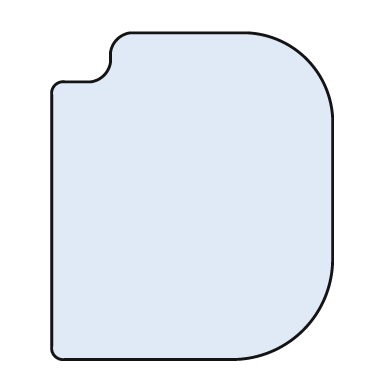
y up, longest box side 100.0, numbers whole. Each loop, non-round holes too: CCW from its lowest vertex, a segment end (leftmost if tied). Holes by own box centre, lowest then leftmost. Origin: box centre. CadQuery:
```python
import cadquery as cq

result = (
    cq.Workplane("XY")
    .moveTo(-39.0, -50.0)
    .lineTo(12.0, -50.0)
    .threePointArc((34.0, -41.0), (43.0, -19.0))
    .lineTo(43.0, 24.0)
    .threePointArc((35.0, 42.0), (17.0, 50.0))
    .lineTo(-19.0, 50.0)
    .threePointArc((-23.0, 48.0), (-25.0, 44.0))
    .lineTo(-25.0, 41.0)
    .threePointArc((-27.0, 37.0), (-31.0, 35.0))
    .lineTo(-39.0, 35.0)
    .threePointArc((-42.0, 34.0), (-43.0, 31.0))
    .lineTo(-43.0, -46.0)
    .threePointArc((-42.0, -49.0), (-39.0, -50.0))
    .close()
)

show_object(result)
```